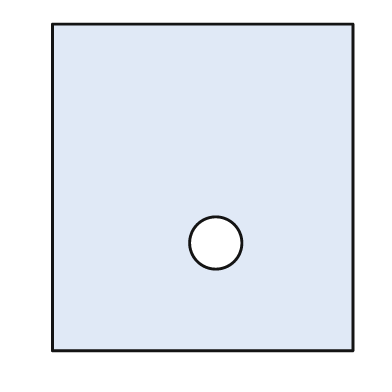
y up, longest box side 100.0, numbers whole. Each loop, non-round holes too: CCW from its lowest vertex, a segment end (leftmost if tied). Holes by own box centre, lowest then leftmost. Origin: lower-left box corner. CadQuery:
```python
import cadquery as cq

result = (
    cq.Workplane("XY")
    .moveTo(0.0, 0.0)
    .lineTo(92.0, 0.0)
    .lineTo(92.0, 100.0)
    .lineTo(0.0, 100.0)
    .close()
    .moveTo(50.0, 33.0)
    .circle(8.0)
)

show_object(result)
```